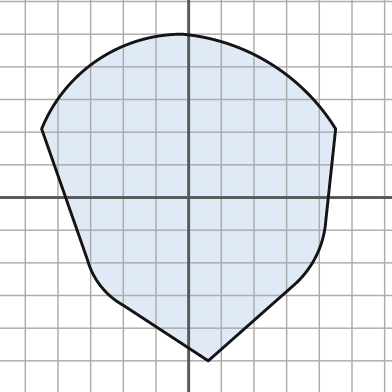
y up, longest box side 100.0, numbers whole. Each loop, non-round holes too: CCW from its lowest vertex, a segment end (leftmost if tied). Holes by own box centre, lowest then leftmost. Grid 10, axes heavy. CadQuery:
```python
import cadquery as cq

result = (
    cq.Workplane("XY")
    .moveTo(6.0, -50.0)
    .lineTo(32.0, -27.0)
    .threePointArc((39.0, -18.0), (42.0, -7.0))
    .lineTo(45.0, 21.0)
    .threePointArc((25.0, 41.0), (-2.0, 50.0))
    .threePointArc((-28.0, 42.0), (-45.0, 21.0))
    .lineTo(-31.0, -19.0)
    .threePointArc((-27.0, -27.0), (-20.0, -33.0))
    .close()
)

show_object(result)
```